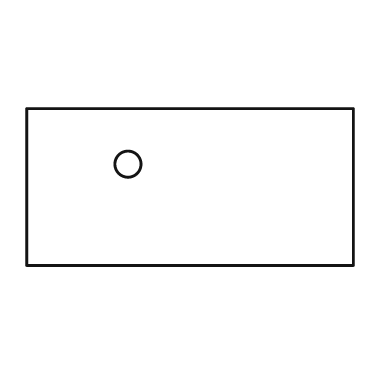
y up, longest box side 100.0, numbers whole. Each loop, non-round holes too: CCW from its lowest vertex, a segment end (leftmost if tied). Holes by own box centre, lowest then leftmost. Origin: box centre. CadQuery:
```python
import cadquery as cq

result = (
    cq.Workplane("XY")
    .moveTo(-50.0, -24.0)
    .lineTo(50.0, -24.0)
    .lineTo(50.0, 24.0)
    .lineTo(-50.0, 24.0)
    .close()
    .moveTo(-19.0, 7.0)
    .circle(4.0)
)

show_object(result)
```